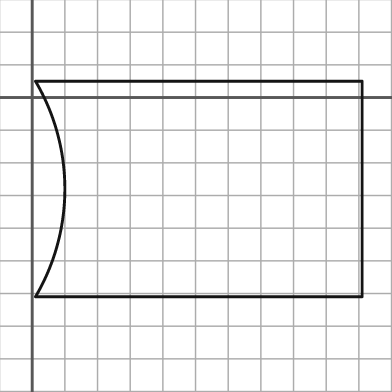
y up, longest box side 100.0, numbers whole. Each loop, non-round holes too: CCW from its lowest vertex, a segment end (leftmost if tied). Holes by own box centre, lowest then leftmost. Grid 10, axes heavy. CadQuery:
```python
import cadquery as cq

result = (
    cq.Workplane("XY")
    .moveTo(1.0, -61.0)
    .lineTo(101.0, -61.0)
    .lineTo(101.0, 5.0)
    .lineTo(1.0, 5.0)
    .threePointArc((10.0, -28.0), (1.0, -61.0))
    .close()
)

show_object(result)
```